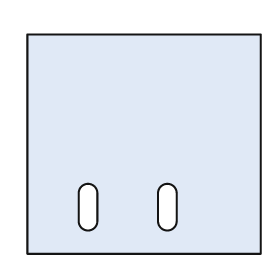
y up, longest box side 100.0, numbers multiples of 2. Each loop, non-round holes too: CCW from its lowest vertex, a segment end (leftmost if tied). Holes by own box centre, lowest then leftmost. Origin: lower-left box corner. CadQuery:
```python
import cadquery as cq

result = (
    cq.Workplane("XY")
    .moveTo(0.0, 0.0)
    .lineTo(100.0, 0.0)
    .lineTo(100.0, 94.0)
    .lineTo(0.0, 94.0)
    .close()
    .moveTo(22.0, 14.0)
    .threePointArc((26.0, 10.0), (30.0, 14.0))
    .lineTo(30.0, 26.0)
    .threePointArc((26.0, 30.0), (22.0, 26.0))
    .close()
    .moveTo(56.0, 14.0)
    .threePointArc((60.0, 10.0), (64.0, 14.0))
    .lineTo(64.0, 26.0)
    .threePointArc((60.0, 30.0), (56.0, 26.0))
    .close()
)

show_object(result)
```